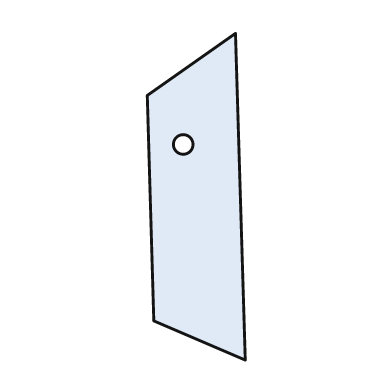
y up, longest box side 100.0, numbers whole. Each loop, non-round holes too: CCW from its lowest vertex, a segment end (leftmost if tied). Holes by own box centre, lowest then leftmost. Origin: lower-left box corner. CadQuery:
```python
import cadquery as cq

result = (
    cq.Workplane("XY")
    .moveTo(30.0, 0.0)
    .lineTo(27.0, 100.0)
    .lineTo(0.0, 81.0)
    .lineTo(2.0, 12.0)
    .close()
    .moveTo(11.0, 66.0)
    .circle(3.0)
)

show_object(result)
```